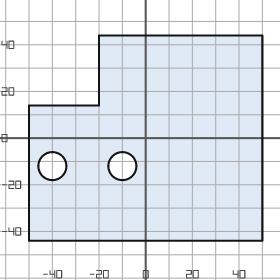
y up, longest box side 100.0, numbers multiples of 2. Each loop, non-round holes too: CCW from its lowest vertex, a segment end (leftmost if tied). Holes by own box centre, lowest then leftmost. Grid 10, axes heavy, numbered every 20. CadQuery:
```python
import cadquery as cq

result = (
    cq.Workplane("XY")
    .moveTo(-50.0, -44.0)
    .lineTo(50.0, -44.0)
    .lineTo(50.0, 44.0)
    .lineTo(-20.0, 44.0)
    .lineTo(-20.0, 14.0)
    .lineTo(-50.0, 14.0)
    .close()
    .moveTo(-40.0, -12.0)
    .circle(6.0)
    .moveTo(-10.0, -12.0)
    .circle(6.0)
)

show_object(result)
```